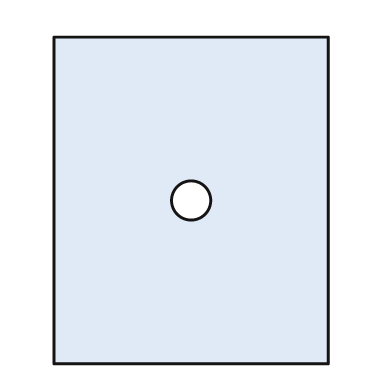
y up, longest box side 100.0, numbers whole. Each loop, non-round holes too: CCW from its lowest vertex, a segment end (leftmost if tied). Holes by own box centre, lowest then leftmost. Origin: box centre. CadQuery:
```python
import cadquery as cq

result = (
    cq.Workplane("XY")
    .moveTo(-42.0, -50.0)
    .lineTo(42.0, -50.0)
    .lineTo(42.0, 50.0)
    .lineTo(-42.0, 50.0)
    .close()
    .moveTo(0.0, 0.0)
    .circle(6.0)
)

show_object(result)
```